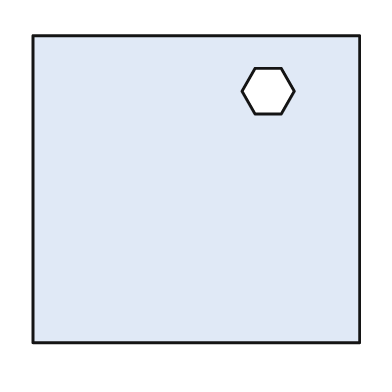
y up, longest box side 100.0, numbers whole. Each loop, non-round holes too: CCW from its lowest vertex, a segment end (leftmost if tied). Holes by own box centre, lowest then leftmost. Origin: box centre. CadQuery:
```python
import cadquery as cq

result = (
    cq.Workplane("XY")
    .moveTo(-50.0, -47.0)
    .lineTo(50.0, -47.0)
    .lineTo(50.0, 47.0)
    .lineTo(-50.0, 47.0)
    .close()
    .moveTo(18.0, 23.0)
    .lineTo(26.0, 23.0)
    .lineTo(30.0, 30.0)
    .lineTo(26.0, 37.0)
    .lineTo(18.0, 37.0)
    .lineTo(14.0, 30.0)
    .close()
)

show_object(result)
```